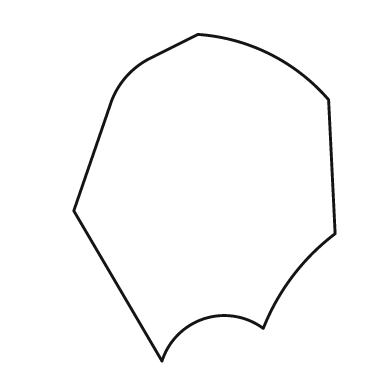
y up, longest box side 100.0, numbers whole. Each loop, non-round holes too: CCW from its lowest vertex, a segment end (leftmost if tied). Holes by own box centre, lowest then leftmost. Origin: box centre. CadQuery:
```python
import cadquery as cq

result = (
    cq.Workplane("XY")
    .moveTo(-13.0, -50.0)
    .threePointArc((0.0, -37.0), (18.0, -40.0))
    .threePointArc((27.0, -24.0), (40.0, -11.0))
    .lineTo(38.0, 30.0)
    .threePointArc((20.0, 44.0), (-2.0, 50.0))
    .lineTo(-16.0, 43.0)
    .threePointArc((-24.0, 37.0), (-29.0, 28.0))
    .lineTo(-40.0, -4.0)
    .close()
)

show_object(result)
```